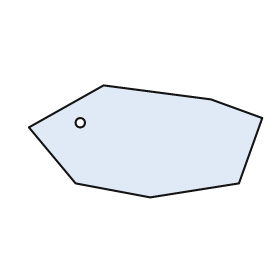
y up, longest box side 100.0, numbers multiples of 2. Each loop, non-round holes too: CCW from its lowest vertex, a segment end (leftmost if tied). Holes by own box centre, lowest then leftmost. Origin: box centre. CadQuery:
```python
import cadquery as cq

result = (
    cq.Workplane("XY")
    .moveTo(2.0, -24.0)
    .lineTo(40.0, -18.0)
    .lineTo(50.0, 10.0)
    .lineTo(28.0, 18.0)
    .lineTo(-18.0, 24.0)
    .lineTo(-50.0, 6.0)
    .lineTo(-30.0, -18.0)
    .close()
    .moveTo(-28.0, 8.0)
    .circle(2.0)
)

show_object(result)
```